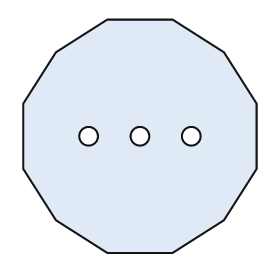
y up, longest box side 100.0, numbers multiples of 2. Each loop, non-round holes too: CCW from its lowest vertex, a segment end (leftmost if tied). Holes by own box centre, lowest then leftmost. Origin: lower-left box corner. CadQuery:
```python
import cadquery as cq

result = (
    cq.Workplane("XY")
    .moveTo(36.0, 0.0)
    .lineTo(64.0, 0.0)
    .lineTo(86.0, 14.0)
    .lineTo(100.0, 36.0)
    .lineTo(100.0, 64.0)
    .lineTo(86.0, 86.0)
    .lineTo(64.0, 100.0)
    .lineTo(36.0, 100.0)
    .lineTo(14.0, 86.0)
    .lineTo(0.0, 64.0)
    .lineTo(0.0, 36.0)
    .lineTo(14.0, 14.0)
    .close()
    .moveTo(28.0, 50.0)
    .circle(4.0)
    .moveTo(50.0, 50.0)
    .circle(4.0)
    .moveTo(72.0, 50.0)
    .circle(4.0)
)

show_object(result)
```